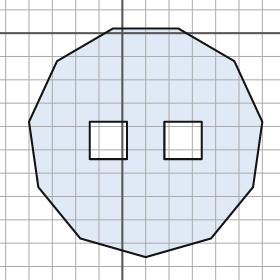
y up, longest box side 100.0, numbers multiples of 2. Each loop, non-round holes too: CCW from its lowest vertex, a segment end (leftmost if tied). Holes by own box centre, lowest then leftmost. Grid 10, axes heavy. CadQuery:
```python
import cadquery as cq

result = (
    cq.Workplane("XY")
    .moveTo(10.0, -96.0)
    .lineTo(38.0, -88.0)
    .lineTo(56.0, -66.0)
    .lineTo(60.0, -38.0)
    .lineTo(48.0, -12.0)
    .lineTo(24.0, 2.0)
    .lineTo(-4.0, 2.0)
    .lineTo(-28.0, -12.0)
    .lineTo(-40.0, -38.0)
    .lineTo(-36.0, -66.0)
    .lineTo(-18.0, -88.0)
    .close()
    .moveTo(-14.0, -54.0)
    .lineTo(2.0, -54.0)
    .lineTo(2.0, -38.0)
    .lineTo(-14.0, -38.0)
    .close()
    .moveTo(18.0, -54.0)
    .lineTo(34.0, -54.0)
    .lineTo(34.0, -38.0)
    .lineTo(18.0, -38.0)
    .close()
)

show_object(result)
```